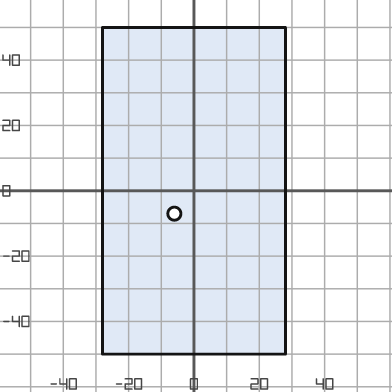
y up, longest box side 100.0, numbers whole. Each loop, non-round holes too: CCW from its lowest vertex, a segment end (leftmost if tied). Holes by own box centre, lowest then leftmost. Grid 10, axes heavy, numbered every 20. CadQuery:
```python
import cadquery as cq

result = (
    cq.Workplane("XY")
    .moveTo(-28.0, -50.0)
    .lineTo(28.0, -50.0)
    .lineTo(28.0, 50.0)
    .lineTo(-28.0, 50.0)
    .close()
    .moveTo(-6.0, -7.0)
    .circle(2.0)
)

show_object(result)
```